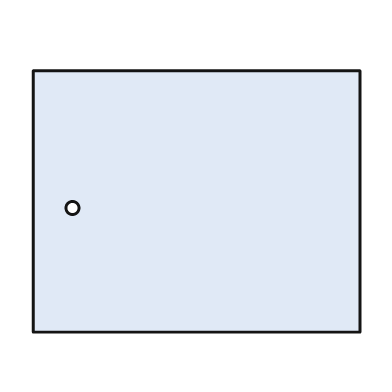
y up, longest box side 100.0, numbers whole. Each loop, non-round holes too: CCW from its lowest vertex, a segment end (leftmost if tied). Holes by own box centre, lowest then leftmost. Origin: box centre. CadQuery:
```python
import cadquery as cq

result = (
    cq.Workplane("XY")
    .moveTo(-50.0, -40.0)
    .lineTo(50.0, -40.0)
    .lineTo(50.0, 40.0)
    .lineTo(-50.0, 40.0)
    .close()
    .moveTo(-38.0, -2.0)
    .circle(2.0)
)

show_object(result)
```